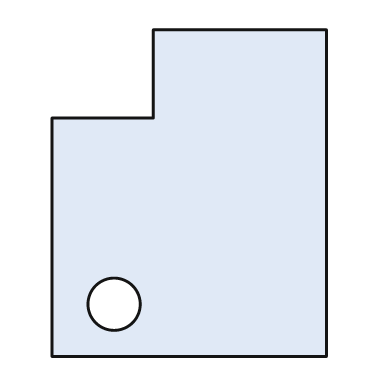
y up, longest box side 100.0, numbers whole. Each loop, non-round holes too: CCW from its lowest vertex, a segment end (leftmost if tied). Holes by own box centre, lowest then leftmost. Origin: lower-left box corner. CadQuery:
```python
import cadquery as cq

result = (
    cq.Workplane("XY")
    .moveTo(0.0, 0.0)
    .lineTo(84.0, 0.0)
    .lineTo(84.0, 100.0)
    .lineTo(31.0, 100.0)
    .lineTo(31.0, 73.0)
    .lineTo(0.0, 73.0)
    .close()
    .moveTo(19.0, 16.0)
    .circle(8.0)
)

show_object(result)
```